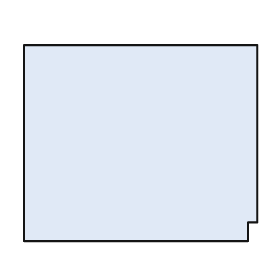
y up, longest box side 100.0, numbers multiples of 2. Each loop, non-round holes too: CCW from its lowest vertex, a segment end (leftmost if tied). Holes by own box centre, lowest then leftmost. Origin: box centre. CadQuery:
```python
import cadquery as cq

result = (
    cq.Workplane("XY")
    .moveTo(-50.0, -42.0)
    .lineTo(46.0, -42.0)
    .lineTo(46.0, -34.0)
    .lineTo(50.0, -34.0)
    .lineTo(50.0, 42.0)
    .lineTo(-50.0, 42.0)
    .close()
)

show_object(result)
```